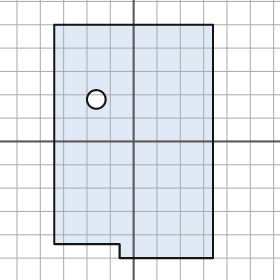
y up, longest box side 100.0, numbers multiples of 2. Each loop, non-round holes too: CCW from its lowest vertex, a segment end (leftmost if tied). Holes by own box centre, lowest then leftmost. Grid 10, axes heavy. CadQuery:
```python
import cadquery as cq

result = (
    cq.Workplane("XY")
    .moveTo(-6.0, -50.0)
    .lineTo(34.0, -50.0)
    .lineTo(34.0, 50.0)
    .lineTo(-34.0, 50.0)
    .lineTo(-34.0, -44.0)
    .lineTo(-6.0, -44.0)
    .close()
    .moveTo(-16.0, 18.0)
    .circle(4.0)
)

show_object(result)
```